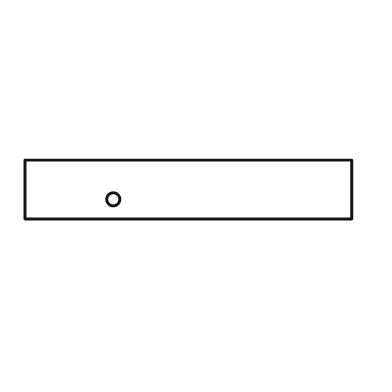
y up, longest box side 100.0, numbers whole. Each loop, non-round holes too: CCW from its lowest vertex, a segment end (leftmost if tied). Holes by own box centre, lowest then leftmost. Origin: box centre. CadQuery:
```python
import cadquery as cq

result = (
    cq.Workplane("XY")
    .moveTo(-50.0, -9.0)
    .lineTo(50.0, -9.0)
    .lineTo(50.0, 9.0)
    .lineTo(-50.0, 9.0)
    .close()
    .moveTo(-23.0, -3.0)
    .circle(2.0)
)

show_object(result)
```